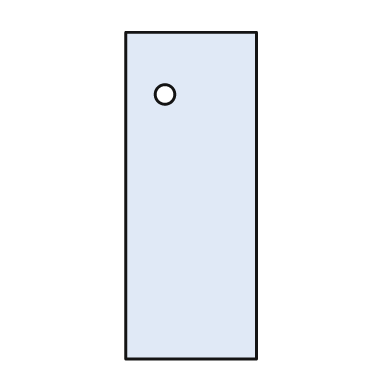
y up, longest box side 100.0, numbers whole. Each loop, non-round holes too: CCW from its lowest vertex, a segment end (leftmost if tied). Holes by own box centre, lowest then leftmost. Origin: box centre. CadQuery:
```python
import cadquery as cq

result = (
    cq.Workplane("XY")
    .moveTo(-20.0, -50.0)
    .lineTo(20.0, -50.0)
    .lineTo(20.0, 50.0)
    .lineTo(-20.0, 50.0)
    .close()
    .moveTo(-8.0, 31.0)
    .circle(3.0)
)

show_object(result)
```